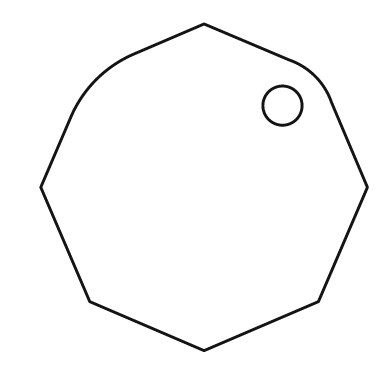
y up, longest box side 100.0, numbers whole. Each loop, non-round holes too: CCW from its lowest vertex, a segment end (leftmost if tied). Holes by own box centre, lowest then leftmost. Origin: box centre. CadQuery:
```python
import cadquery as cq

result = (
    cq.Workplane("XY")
    .moveTo(0.0, -50.0)
    .lineTo(35.0, -35.0)
    .lineTo(50.0, 0.0)
    .lineTo(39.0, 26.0)
    .threePointArc((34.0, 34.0), (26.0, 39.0))
    .lineTo(0.0, 50.0)
    .lineTo(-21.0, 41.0)
    .threePointArc((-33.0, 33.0), (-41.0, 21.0))
    .lineTo(-50.0, 0.0)
    .lineTo(-35.0, -35.0)
    .close()
    .moveTo(24.0, 25.0)
    .circle(6.0)
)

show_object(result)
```